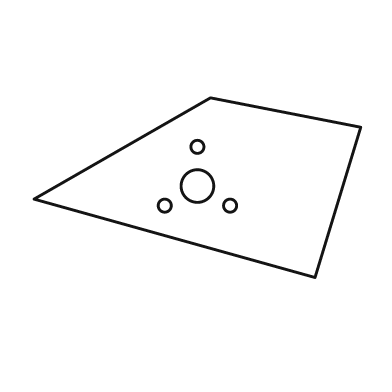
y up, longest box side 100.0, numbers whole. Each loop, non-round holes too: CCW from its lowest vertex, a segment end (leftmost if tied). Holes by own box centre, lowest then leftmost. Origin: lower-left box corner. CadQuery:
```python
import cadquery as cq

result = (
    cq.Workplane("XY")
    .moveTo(86.0, 0.0)
    .lineTo(100.0, 46.0)
    .lineTo(54.0, 55.0)
    .lineTo(0.0, 24.0)
    .close()
    .moveTo(40.0, 22.0)
    .circle(2.0)
    .moveTo(60.0, 22.0)
    .circle(2.0)
    .moveTo(50.0, 28.0)
    .circle(5.0)
    .moveTo(50.0, 40.0)
    .circle(2.0)
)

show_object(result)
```